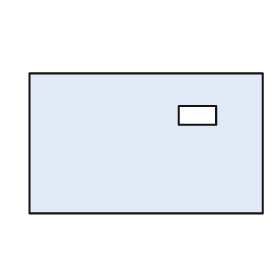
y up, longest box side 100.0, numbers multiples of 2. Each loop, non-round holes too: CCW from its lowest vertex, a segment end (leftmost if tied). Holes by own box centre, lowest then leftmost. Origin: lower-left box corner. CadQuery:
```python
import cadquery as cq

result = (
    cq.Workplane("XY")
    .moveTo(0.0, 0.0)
    .lineTo(100.0, 0.0)
    .lineTo(100.0, 60.0)
    .lineTo(0.0, 60.0)
    .close()
    .moveTo(64.0, 38.0)
    .lineTo(80.0, 38.0)
    .lineTo(80.0, 46.0)
    .lineTo(64.0, 46.0)
    .close()
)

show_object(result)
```